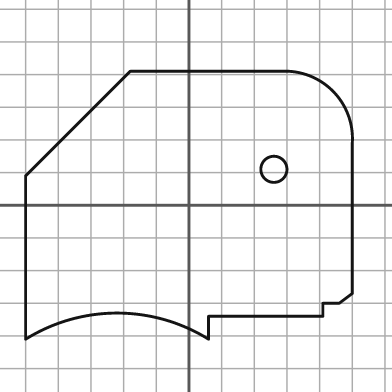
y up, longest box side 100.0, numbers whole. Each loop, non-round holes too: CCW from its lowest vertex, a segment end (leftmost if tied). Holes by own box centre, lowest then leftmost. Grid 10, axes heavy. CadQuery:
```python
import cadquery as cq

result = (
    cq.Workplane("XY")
    .moveTo(-50.0, -41.0)
    .threePointArc((-22.0, -33.0), (6.0, -41.0))
    .lineTo(6.0, -34.0)
    .lineTo(41.0, -34.0)
    .lineTo(41.0, -30.0)
    .lineTo(46.0, -30.0)
    .lineTo(50.0, -27.0)
    .lineTo(50.0, 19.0)
    .threePointArc((44.0, 35.0), (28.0, 41.0))
    .lineTo(-18.0, 41.0)
    .lineTo(-50.0, 9.0)
    .close()
    .moveTo(26.0, 11.0)
    .circle(4.0)
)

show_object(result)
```